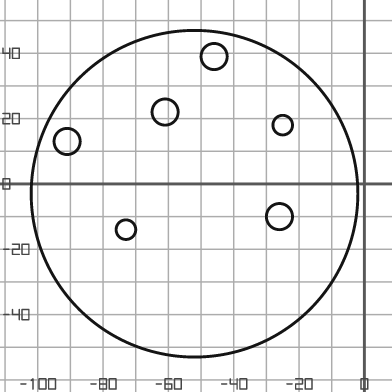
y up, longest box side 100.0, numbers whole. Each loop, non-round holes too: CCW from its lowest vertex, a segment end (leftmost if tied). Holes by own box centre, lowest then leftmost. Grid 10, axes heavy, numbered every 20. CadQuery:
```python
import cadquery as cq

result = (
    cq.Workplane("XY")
    .moveTo(-52.0, -3.0)
    .circle(50.0)
    .moveTo(-73.0, -14.0)
    .circle(3.0)
    .moveTo(-26.0, -10.0)
    .circle(4.0)
    .moveTo(-91.0, 13.0)
    .circle(4.0)
    .moveTo(-25.0, 18.0)
    .circle(3.0)
    .moveTo(-61.0, 22.0)
    .circle(4.0)
    .moveTo(-46.0, 39.0)
    .circle(4.0)
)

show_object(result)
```